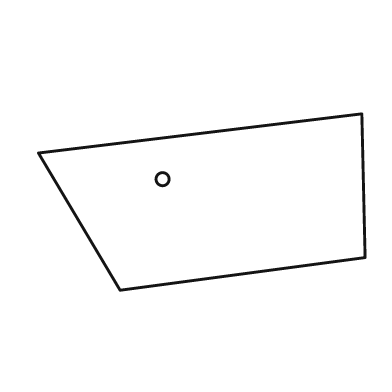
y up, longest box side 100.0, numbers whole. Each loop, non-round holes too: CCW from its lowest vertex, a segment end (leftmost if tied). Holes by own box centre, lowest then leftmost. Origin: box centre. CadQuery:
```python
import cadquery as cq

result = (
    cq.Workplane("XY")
    .moveTo(-25.0, -27.0)
    .lineTo(50.0, -17.0)
    .lineTo(49.0, 27.0)
    .lineTo(-50.0, 15.0)
    .close()
    .moveTo(-12.0, 7.0)
    .circle(2.0)
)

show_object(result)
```